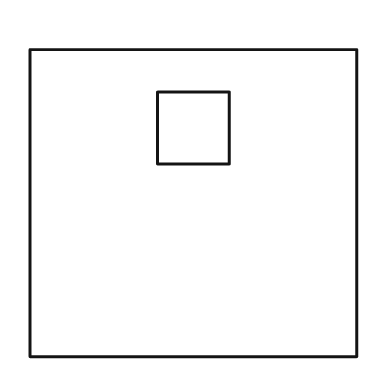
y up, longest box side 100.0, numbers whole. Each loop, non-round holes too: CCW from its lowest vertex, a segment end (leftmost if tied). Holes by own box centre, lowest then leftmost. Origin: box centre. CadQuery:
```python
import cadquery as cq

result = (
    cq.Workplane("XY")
    .moveTo(-50.0, -47.0)
    .lineTo(50.0, -47.0)
    .lineTo(50.0, 47.0)
    .lineTo(-50.0, 47.0)
    .close()
    .moveTo(-11.0, 12.0)
    .lineTo(11.0, 12.0)
    .lineTo(11.0, 34.0)
    .lineTo(-11.0, 34.0)
    .close()
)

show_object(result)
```